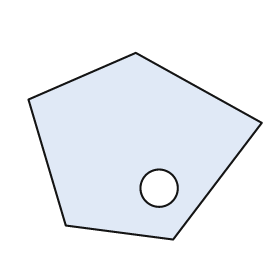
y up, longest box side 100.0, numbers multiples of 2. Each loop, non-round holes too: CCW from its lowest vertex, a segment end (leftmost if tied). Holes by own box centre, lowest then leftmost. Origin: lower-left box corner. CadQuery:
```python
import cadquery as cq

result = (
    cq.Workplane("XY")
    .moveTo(62.0, 0.0)
    .lineTo(100.0, 50.0)
    .lineTo(46.0, 80.0)
    .lineTo(0.0, 60.0)
    .lineTo(16.0, 6.0)
    .close()
    .moveTo(56.0, 22.0)
    .circle(8.0)
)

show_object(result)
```